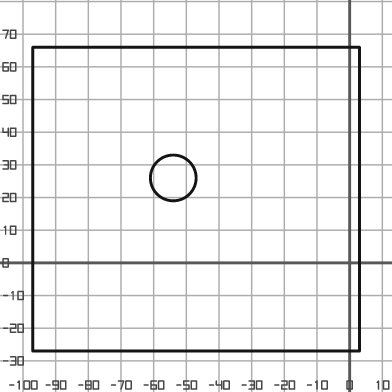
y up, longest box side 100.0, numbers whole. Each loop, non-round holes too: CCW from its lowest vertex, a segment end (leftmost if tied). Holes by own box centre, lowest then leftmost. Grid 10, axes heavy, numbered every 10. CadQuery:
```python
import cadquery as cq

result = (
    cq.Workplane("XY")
    .moveTo(-97.0, -27.0)
    .lineTo(3.0, -27.0)
    .lineTo(3.0, 66.0)
    .lineTo(-97.0, 66.0)
    .close()
    .moveTo(-54.0, 26.0)
    .circle(7.0)
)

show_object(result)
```